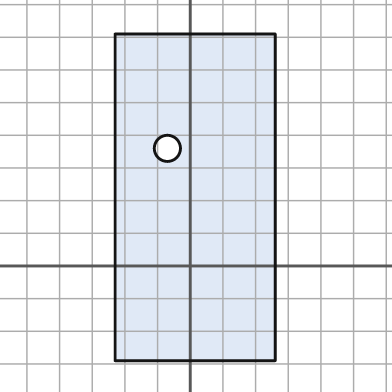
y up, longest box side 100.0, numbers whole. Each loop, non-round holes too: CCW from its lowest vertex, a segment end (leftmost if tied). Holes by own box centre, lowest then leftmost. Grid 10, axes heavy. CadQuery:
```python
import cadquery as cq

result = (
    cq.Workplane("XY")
    .moveTo(-23.0, -29.0)
    .lineTo(26.0, -29.0)
    .lineTo(26.0, 71.0)
    .lineTo(-23.0, 71.0)
    .close()
    .moveTo(-7.0, 36.0)
    .circle(4.0)
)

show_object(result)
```